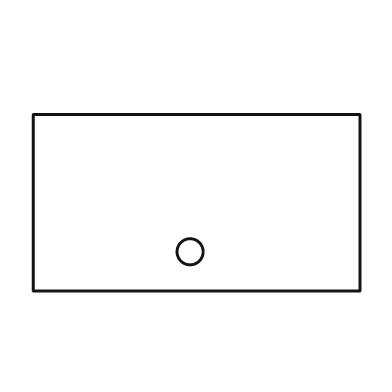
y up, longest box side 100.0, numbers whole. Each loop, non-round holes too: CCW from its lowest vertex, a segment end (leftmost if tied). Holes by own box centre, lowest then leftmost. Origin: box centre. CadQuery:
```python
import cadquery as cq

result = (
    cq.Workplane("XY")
    .moveTo(-50.0, -27.0)
    .lineTo(50.0, -27.0)
    .lineTo(50.0, 27.0)
    .lineTo(-50.0, 27.0)
    .close()
    .moveTo(-2.0, -15.0)
    .circle(4.0)
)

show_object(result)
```